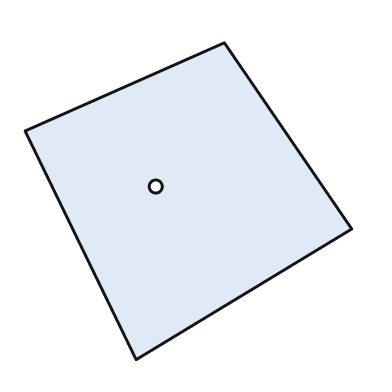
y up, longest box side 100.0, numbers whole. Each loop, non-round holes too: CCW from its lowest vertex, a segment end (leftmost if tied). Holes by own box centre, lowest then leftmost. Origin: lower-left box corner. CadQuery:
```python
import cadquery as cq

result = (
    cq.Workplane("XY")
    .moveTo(34.0, 0.0)
    .lineTo(100.0, 40.0)
    .lineTo(61.0, 97.0)
    .lineTo(0.0, 70.0)
    .close()
    .moveTo(40.0, 53.0)
    .circle(2.0)
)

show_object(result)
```